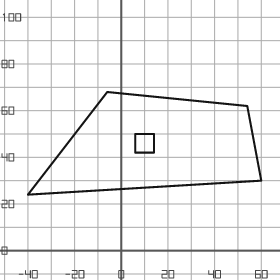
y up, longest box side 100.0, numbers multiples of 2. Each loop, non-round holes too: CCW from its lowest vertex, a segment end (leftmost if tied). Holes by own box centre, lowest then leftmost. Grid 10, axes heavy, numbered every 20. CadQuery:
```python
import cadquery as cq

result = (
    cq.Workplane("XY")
    .moveTo(-40.0, 24.0)
    .lineTo(60.0, 30.0)
    .lineTo(54.0, 62.0)
    .lineTo(-6.0, 68.0)
    .close()
    .moveTo(6.0, 42.0)
    .lineTo(14.0, 42.0)
    .lineTo(14.0, 50.0)
    .lineTo(6.0, 50.0)
    .close()
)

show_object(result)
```